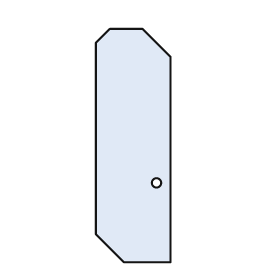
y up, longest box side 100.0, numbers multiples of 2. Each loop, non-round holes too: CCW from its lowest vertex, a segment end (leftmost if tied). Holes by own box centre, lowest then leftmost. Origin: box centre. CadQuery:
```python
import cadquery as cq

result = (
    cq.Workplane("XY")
    .moveTo(-4.0, -50.0)
    .lineTo(16.0, -50.0)
    .lineTo(16.0, 38.0)
    .lineTo(4.0, 50.0)
    .lineTo(-10.0, 50.0)
    .lineTo(-16.0, 44.0)
    .lineTo(-16.0, -38.0)
    .close()
    .moveTo(10.0, -16.0)
    .circle(2.0)
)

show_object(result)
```